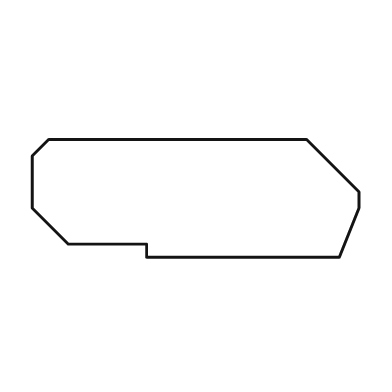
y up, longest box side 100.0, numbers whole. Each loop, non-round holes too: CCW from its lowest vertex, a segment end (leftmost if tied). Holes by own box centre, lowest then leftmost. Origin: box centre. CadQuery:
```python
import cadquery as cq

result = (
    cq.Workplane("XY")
    .moveTo(-15.0, -18.0)
    .lineTo(44.0, -18.0)
    .lineTo(50.0, -3.0)
    .lineTo(50.0, 2.0)
    .lineTo(34.0, 18.0)
    .lineTo(-45.0, 18.0)
    .lineTo(-50.0, 13.0)
    .lineTo(-50.0, -3.0)
    .lineTo(-39.0, -14.0)
    .lineTo(-15.0, -14.0)
    .close()
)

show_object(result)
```